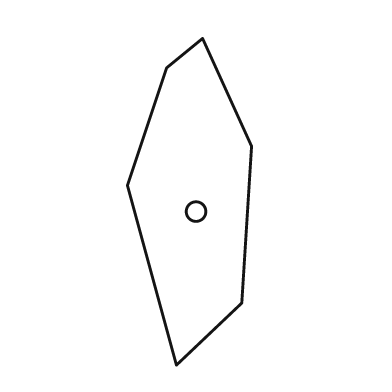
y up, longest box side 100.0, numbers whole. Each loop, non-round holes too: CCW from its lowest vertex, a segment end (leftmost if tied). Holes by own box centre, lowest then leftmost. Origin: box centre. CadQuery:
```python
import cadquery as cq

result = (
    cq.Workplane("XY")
    .moveTo(-4.0, -50.0)
    .lineTo(16.0, -31.0)
    .lineTo(19.0, 17.0)
    .lineTo(4.0, 50.0)
    .lineTo(-7.0, 41.0)
    .lineTo(-19.0, 5.0)
    .close()
    .moveTo(2.0, -3.0)
    .circle(3.0)
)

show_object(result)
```